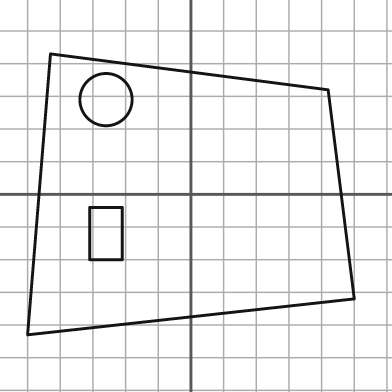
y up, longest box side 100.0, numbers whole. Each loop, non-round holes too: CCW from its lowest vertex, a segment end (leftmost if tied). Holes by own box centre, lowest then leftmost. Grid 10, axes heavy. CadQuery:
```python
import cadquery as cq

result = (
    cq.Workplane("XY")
    .moveTo(-50.0, -43.0)
    .lineTo(50.0, -32.0)
    .lineTo(42.0, 32.0)
    .lineTo(-43.0, 43.0)
    .close()
    .moveTo(-31.0, -20.0)
    .lineTo(-21.0, -20.0)
    .lineTo(-21.0, -4.0)
    .lineTo(-31.0, -4.0)
    .close()
    .moveTo(-26.0, 29.0)
    .circle(8.0)
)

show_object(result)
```